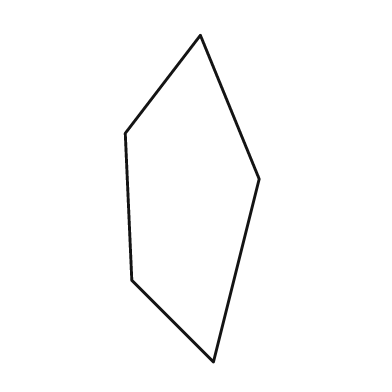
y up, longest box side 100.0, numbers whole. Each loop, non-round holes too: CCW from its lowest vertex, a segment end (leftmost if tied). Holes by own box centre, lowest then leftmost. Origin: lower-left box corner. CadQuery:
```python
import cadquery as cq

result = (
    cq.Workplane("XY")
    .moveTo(27.0, 0.0)
    .lineTo(41.0, 56.0)
    .lineTo(23.0, 100.0)
    .lineTo(0.0, 70.0)
    .lineTo(2.0, 25.0)
    .close()
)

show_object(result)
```